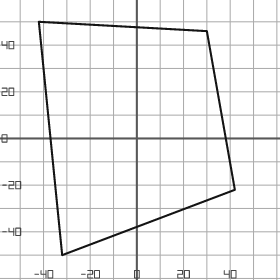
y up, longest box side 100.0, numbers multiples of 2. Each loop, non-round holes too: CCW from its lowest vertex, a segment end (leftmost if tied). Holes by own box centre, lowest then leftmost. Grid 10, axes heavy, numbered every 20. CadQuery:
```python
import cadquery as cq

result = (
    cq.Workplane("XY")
    .moveTo(-32.0, -50.0)
    .lineTo(42.0, -22.0)
    .lineTo(30.0, 46.0)
    .lineTo(-42.0, 50.0)
    .close()
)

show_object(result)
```